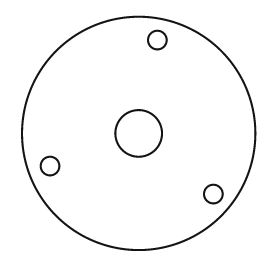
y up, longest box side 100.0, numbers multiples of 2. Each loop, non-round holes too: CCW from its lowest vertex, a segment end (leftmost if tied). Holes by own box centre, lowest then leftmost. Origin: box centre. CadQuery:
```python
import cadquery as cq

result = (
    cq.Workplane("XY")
    .moveTo(0.0, 0.0)
    .circle(50.0)
    .moveTo(32.0, -26.0)
    .circle(4.0)
    .moveTo(-38.0, -14.0)
    .circle(4.0)
    .moveTo(0.0, 0.0)
    .circle(10.0)
    .moveTo(8.0, 40.0)
    .circle(4.0)
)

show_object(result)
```